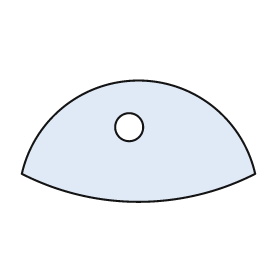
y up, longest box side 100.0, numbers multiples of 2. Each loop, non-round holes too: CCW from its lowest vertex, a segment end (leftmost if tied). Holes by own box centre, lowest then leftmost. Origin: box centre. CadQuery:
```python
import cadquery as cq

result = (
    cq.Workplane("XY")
    .moveTo(-50.0, -14.0)
    .threePointArc((0.0, -26.0), (50.0, -14.0))
    .threePointArc((0.0, 26.0), (-50.0, -14.0))
    .close()
    .moveTo(-4.0, 6.0)
    .circle(6.0)
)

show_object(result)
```